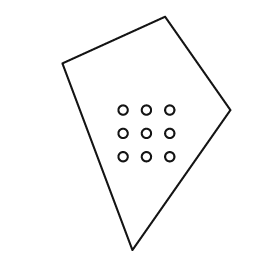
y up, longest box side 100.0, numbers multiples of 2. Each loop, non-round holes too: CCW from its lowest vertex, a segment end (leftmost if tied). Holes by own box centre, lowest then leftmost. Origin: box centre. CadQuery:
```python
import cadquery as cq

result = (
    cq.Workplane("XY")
    .moveTo(-6.0, -50.0)
    .lineTo(36.0, 10.0)
    .lineTo(8.0, 50.0)
    .lineTo(-36.0, 30.0)
    .close()
    .moveTo(-10.0, -10.0)
    .circle(2.0)
    .moveTo(0.0, -10.0)
    .circle(2.0)
    .moveTo(10.0, -10.0)
    .circle(2.0)
    .moveTo(-10.0, 0.0)
    .circle(2.0)
    .moveTo(0.0, 0.0)
    .circle(2.0)
    .moveTo(10.0, 0.0)
    .circle(2.0)
    .moveTo(-10.0, 10.0)
    .circle(2.0)
    .moveTo(0.0, 10.0)
    .circle(2.0)
    .moveTo(10.0, 10.0)
    .circle(2.0)
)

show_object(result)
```